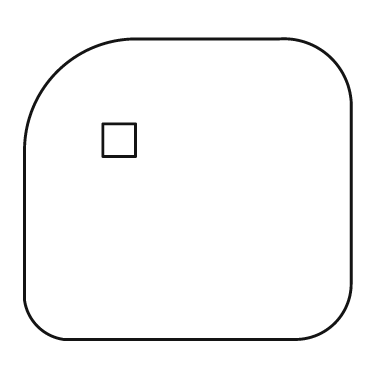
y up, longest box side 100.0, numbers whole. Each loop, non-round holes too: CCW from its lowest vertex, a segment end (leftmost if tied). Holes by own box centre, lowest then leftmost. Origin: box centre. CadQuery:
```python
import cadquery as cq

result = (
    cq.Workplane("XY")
    .moveTo(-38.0, -46.0)
    .lineTo(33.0, -46.0)
    .threePointArc((45.0, -41.0), (50.0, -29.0))
    .lineTo(50.0, 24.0)
    .threePointArc((44.0, 40.0), (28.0, 46.0))
    .lineTo(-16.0, 46.0)
    .threePointArc((-40.0, 36.0), (-50.0, 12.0))
    .lineTo(-50.0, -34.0)
    .threePointArc((-46.0, -42.0), (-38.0, -46.0))
    .close()
    .moveTo(-26.0, 10.0)
    .lineTo(-16.0, 10.0)
    .lineTo(-16.0, 20.0)
    .lineTo(-26.0, 20.0)
    .close()
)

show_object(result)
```